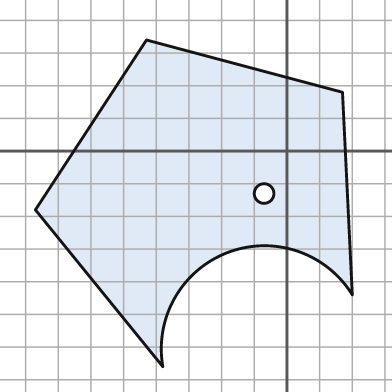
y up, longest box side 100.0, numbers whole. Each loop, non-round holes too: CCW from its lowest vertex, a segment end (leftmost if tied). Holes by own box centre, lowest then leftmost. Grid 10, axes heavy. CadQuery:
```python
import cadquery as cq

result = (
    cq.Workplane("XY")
    .moveTo(-38.0, -66.0)
    .threePointArc((-18.0, -31.0), (20.0, -44.0))
    .lineTo(17.0, 18.0)
    .lineTo(-43.0, 34.0)
    .lineTo(-77.0, -18.0)
    .close()
    .moveTo(-7.0, -13.0)
    .circle(3.0)
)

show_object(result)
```